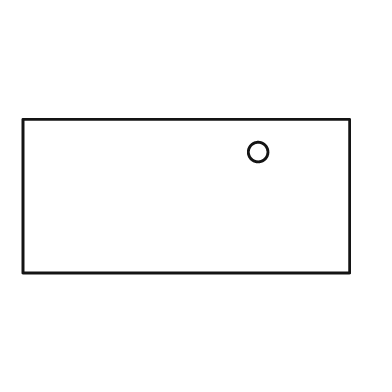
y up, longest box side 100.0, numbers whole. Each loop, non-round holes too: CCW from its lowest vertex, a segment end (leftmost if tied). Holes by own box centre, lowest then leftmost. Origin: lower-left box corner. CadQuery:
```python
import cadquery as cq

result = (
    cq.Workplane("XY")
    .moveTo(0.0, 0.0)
    .lineTo(100.0, 0.0)
    .lineTo(100.0, 47.0)
    .lineTo(0.0, 47.0)
    .close()
    .moveTo(72.0, 37.0)
    .circle(3.0)
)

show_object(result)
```